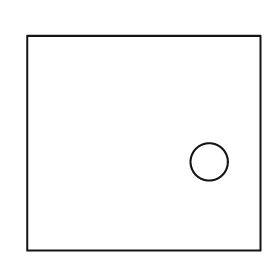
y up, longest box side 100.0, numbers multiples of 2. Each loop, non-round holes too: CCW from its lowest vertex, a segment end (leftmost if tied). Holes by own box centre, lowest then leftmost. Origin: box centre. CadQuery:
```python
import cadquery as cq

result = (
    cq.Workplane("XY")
    .moveTo(-50.0, -46.0)
    .lineTo(50.0, -46.0)
    .lineTo(50.0, 46.0)
    .lineTo(-50.0, 46.0)
    .close()
    .moveTo(28.0, -8.0)
    .circle(8.0)
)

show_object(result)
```